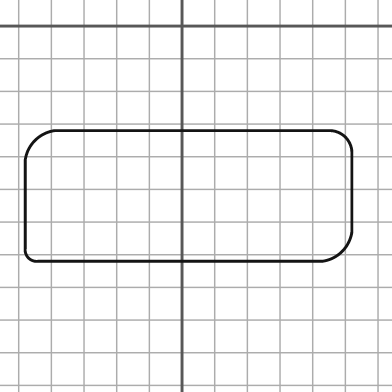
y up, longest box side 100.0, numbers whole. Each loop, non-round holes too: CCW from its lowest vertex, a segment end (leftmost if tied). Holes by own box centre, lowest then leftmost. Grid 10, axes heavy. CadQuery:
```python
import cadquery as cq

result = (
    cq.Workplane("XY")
    .moveTo(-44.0, -72.0)
    .lineTo(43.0, -72.0)
    .threePointArc((49.0, -69.0), (52.0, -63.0))
    .lineTo(52.0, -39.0)
    .threePointArc((50.0, -34.0), (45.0, -32.0))
    .lineTo(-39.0, -32.0)
    .threePointArc((-45.0, -35.0), (-48.0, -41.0))
    .lineTo(-48.0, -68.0)
    .threePointArc((-47.0, -71.0), (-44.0, -72.0))
    .close()
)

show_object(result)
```